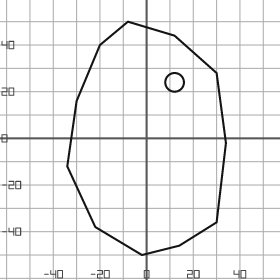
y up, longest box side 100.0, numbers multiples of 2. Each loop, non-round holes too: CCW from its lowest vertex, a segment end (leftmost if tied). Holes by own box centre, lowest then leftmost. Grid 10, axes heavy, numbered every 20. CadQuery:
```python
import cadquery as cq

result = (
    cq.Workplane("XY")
    .moveTo(-2.0, -50.0)
    .lineTo(14.0, -46.0)
    .lineTo(30.0, -36.0)
    .lineTo(34.0, -2.0)
    .lineTo(30.0, 28.0)
    .lineTo(12.0, 44.0)
    .lineTo(-8.0, 50.0)
    .lineTo(-20.0, 40.0)
    .lineTo(-30.0, 16.0)
    .lineTo(-34.0, -12.0)
    .lineTo(-22.0, -38.0)
    .close()
    .moveTo(12.0, 24.0)
    .circle(4.0)
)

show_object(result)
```